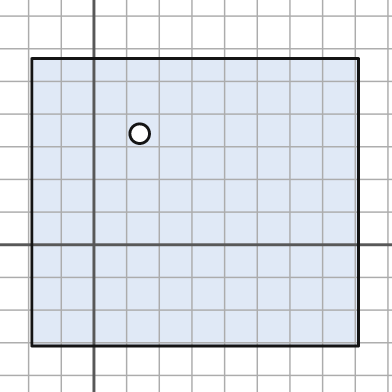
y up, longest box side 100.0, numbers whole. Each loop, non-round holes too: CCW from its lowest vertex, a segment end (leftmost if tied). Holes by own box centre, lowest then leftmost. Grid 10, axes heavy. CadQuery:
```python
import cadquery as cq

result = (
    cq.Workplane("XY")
    .moveTo(-19.0, -31.0)
    .lineTo(81.0, -31.0)
    .lineTo(81.0, 57.0)
    .lineTo(-19.0, 57.0)
    .close()
    .moveTo(14.0, 34.0)
    .circle(3.0)
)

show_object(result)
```